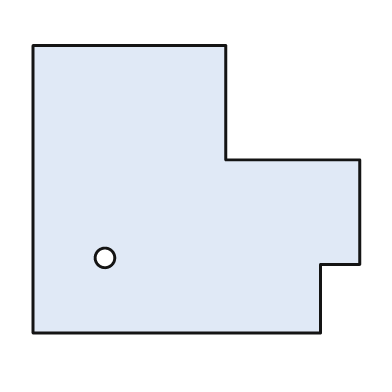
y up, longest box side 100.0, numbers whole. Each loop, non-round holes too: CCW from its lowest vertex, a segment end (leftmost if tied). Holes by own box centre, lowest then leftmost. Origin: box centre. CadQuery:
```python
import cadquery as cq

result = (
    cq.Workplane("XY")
    .moveTo(-50.0, -44.0)
    .lineTo(38.0, -44.0)
    .lineTo(38.0, -23.0)
    .lineTo(50.0, -23.0)
    .lineTo(50.0, 9.0)
    .lineTo(9.0, 9.0)
    .lineTo(9.0, 44.0)
    .lineTo(-50.0, 44.0)
    .close()
    .moveTo(-28.0, -21.0)
    .circle(3.0)
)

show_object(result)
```